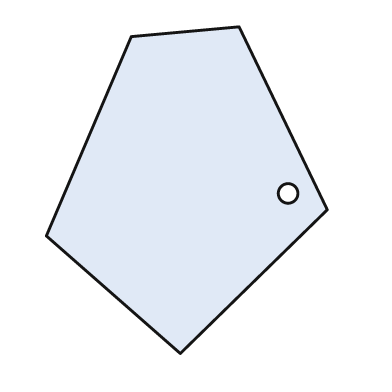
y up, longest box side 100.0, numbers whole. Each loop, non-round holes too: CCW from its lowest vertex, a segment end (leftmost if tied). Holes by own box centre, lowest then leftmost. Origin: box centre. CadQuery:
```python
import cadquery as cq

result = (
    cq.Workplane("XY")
    .moveTo(-2.0, -50.0)
    .lineTo(43.0, -6.0)
    .lineTo(16.0, 50.0)
    .lineTo(-17.0, 47.0)
    .lineTo(-43.0, -14.0)
    .close()
    .moveTo(31.0, -1.0)
    .circle(3.0)
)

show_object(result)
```